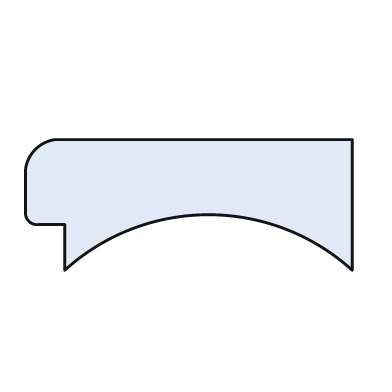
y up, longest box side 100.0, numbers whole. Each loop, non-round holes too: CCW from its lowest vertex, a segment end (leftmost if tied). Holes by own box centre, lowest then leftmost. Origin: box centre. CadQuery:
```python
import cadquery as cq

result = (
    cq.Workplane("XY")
    .moveTo(-38.0, -20.0)
    .threePointArc((6.0, -3.0), (50.0, -20.0))
    .lineTo(50.0, 20.0)
    .lineTo(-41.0, 20.0)
    .threePointArc((-47.0, 17.0), (-50.0, 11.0))
    .lineTo(-50.0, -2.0)
    .threePointArc((-49.0, -5.0), (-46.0, -6.0))
    .lineTo(-38.0, -6.0)
    .close()
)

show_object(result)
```